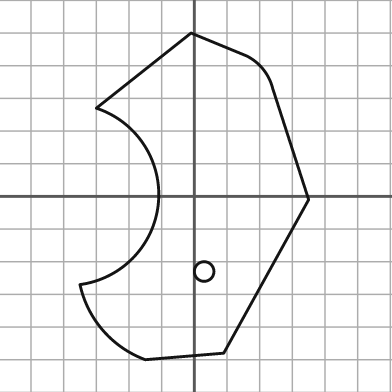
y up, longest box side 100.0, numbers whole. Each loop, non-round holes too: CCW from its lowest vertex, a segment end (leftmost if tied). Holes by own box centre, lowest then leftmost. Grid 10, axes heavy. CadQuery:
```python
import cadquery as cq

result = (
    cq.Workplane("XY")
    .moveTo(-15.0, -50.0)
    .lineTo(9.0, -48.0)
    .lineTo(35.0, -1.0)
    .lineTo(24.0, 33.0)
    .threePointArc((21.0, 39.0), (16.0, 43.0))
    .lineTo(-1.0, 50.0)
    .lineTo(-30.0, 27.0)
    .threePointArc((-11.0, -2.0), (-35.0, -27.0))
    .threePointArc((-28.0, -41.0), (-15.0, -50.0))
    .close()
    .moveTo(3.0, -23.0)
    .circle(3.0)
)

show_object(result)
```